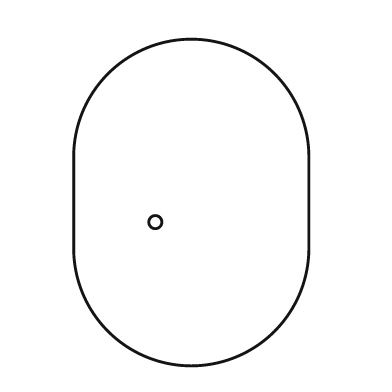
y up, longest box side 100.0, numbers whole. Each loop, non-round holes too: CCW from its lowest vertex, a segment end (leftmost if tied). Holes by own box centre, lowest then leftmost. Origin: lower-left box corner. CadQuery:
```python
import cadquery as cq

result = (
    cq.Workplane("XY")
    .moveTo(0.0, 36.0)
    .threePointArc((36.0, 0.0), (72.0, 36.0))
    .lineTo(72.0, 64.0)
    .threePointArc((36.0, 100.0), (0.0, 64.0))
    .close()
    .moveTo(25.0, 44.0)
    .circle(2.0)
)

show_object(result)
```